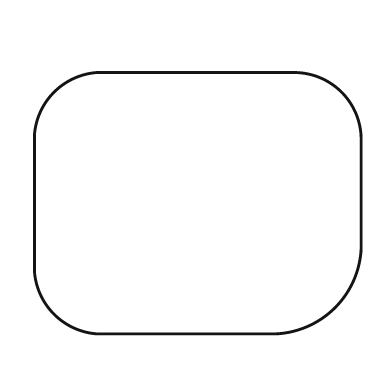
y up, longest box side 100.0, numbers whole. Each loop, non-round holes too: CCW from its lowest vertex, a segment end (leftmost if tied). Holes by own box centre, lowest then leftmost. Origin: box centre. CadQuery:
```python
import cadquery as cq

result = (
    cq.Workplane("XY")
    .moveTo(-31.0, -40.0)
    .lineTo(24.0, -40.0)
    .threePointArc((42.0, -32.0), (50.0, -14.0))
    .lineTo(50.0, 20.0)
    .threePointArc((44.0, 34.0), (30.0, 40.0))
    .lineTo(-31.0, 40.0)
    .threePointArc((-44.0, 34.0), (-50.0, 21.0))
    .lineTo(-50.0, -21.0)
    .threePointArc((-44.0, -34.0), (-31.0, -40.0))
    .close()
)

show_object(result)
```